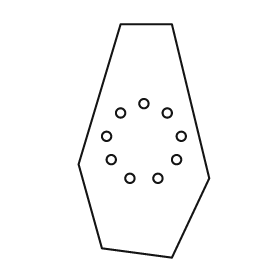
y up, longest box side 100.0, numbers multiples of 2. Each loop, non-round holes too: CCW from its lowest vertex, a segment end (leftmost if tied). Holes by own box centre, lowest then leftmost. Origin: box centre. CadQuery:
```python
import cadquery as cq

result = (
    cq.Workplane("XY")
    .moveTo(12.0, -50.0)
    .lineTo(28.0, -16.0)
    .lineTo(12.0, 50.0)
    .lineTo(-10.0, 50.0)
    .lineTo(-28.0, -10.0)
    .lineTo(-18.0, -46.0)
    .close()
    .moveTo(-6.0, -16.0)
    .circle(2.0)
    .moveTo(6.0, -16.0)
    .circle(2.0)
    .moveTo(-14.0, -8.0)
    .circle(2.0)
    .moveTo(14.0, -8.0)
    .circle(2.0)
    .moveTo(-16.0, 2.0)
    .circle(2.0)
    .moveTo(16.0, 2.0)
    .circle(2.0)
    .moveTo(-10.0, 12.0)
    .circle(2.0)
    .moveTo(10.0, 12.0)
    .circle(2.0)
    .moveTo(0.0, 16.0)
    .circle(2.0)
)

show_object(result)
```